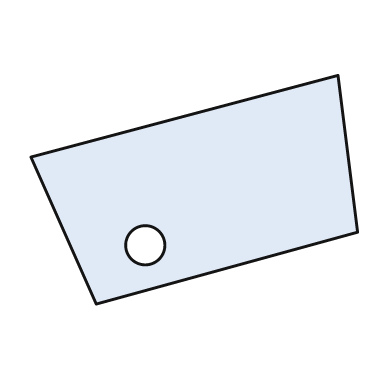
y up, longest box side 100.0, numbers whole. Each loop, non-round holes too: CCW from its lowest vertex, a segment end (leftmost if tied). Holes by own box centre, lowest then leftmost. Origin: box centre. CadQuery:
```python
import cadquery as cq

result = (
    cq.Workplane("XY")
    .moveTo(-30.0, -35.0)
    .lineTo(50.0, -13.0)
    .lineTo(44.0, 35.0)
    .lineTo(-50.0, 10.0)
    .close()
    .moveTo(-15.0, -17.0)
    .circle(6.0)
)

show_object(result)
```